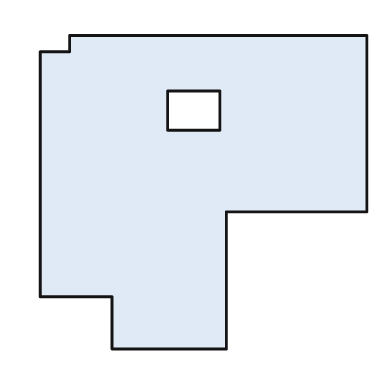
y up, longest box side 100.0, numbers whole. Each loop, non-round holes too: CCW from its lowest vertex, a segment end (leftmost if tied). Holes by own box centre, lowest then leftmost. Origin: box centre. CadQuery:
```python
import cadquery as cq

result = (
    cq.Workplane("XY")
    .moveTo(-28.0, -48.0)
    .lineTo(7.0, -48.0)
    .lineTo(7.0, -6.0)
    .lineTo(50.0, -6.0)
    .lineTo(50.0, 48.0)
    .lineTo(-41.0, 48.0)
    .lineTo(-41.0, 43.0)
    .lineTo(-50.0, 43.0)
    .lineTo(-50.0, -32.0)
    .lineTo(-28.0, -32.0)
    .close()
    .moveTo(-11.0, 19.0)
    .lineTo(5.0, 19.0)
    .lineTo(5.0, 31.0)
    .lineTo(-11.0, 31.0)
    .close()
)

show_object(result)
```